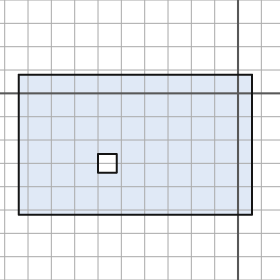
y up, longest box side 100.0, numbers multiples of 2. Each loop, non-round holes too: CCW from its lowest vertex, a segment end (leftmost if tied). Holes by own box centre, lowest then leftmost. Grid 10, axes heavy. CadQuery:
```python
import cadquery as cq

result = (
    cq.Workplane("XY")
    .moveTo(-94.0, -52.0)
    .lineTo(6.0, -52.0)
    .lineTo(6.0, 8.0)
    .lineTo(-94.0, 8.0)
    .close()
    .moveTo(-60.0, -34.0)
    .lineTo(-52.0, -34.0)
    .lineTo(-52.0, -26.0)
    .lineTo(-60.0, -26.0)
    .close()
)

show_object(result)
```